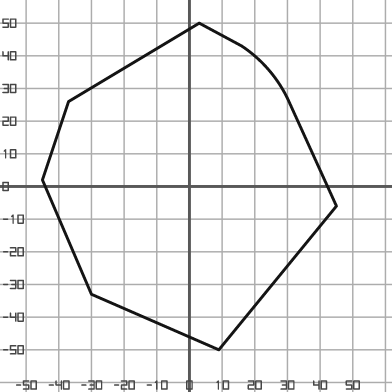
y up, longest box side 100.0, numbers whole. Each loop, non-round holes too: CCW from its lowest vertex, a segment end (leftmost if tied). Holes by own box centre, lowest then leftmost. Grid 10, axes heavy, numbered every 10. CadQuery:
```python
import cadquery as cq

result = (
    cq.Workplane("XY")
    .moveTo(9.0, -50.0)
    .lineTo(45.0, -6.0)
    .lineTo(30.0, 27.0)
    .threePointArc((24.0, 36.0), (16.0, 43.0))
    .lineTo(3.0, 50.0)
    .lineTo(-37.0, 26.0)
    .lineTo(-45.0, 2.0)
    .lineTo(-30.0, -33.0)
    .close()
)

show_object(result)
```